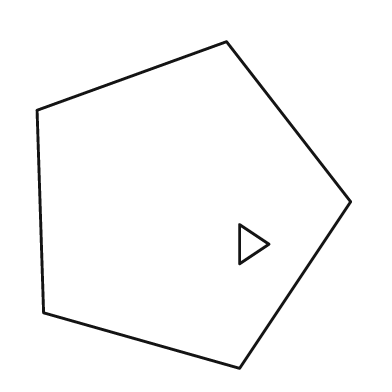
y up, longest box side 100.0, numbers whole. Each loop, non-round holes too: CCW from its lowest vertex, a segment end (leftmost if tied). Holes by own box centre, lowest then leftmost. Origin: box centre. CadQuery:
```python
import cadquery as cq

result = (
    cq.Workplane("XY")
    .moveTo(14.0, -50.0)
    .lineTo(48.0, 1.0)
    .lineTo(10.0, 50.0)
    .lineTo(-48.0, 29.0)
    .lineTo(-46.0, -33.0)
    .close()
    .moveTo(14.0, -18.0)
    .lineTo(23.0, -12.0)
    .lineTo(14.0, -6.0)
    .close()
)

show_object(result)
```